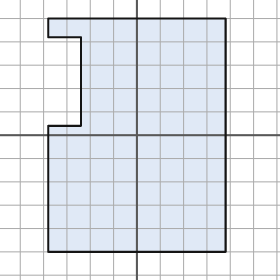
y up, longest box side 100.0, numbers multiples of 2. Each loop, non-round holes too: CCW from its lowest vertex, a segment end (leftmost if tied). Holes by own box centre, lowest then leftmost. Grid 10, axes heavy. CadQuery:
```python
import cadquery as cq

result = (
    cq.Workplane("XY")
    .moveTo(-38.0, -50.0)
    .lineTo(38.0, -50.0)
    .lineTo(38.0, 50.0)
    .lineTo(-38.0, 50.0)
    .lineTo(-38.0, 42.0)
    .lineTo(-24.0, 42.0)
    .lineTo(-24.0, 4.0)
    .lineTo(-38.0, 4.0)
    .close()
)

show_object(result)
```